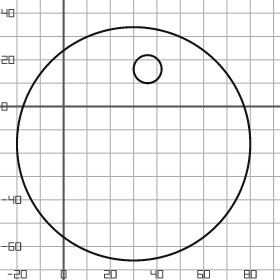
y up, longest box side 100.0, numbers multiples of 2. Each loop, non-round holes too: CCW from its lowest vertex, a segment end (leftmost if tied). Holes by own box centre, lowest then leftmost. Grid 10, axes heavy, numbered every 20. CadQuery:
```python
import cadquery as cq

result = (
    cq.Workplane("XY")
    .moveTo(30.0, -16.0)
    .circle(50.0)
    .moveTo(36.0, 16.0)
    .circle(6.0)
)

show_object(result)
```